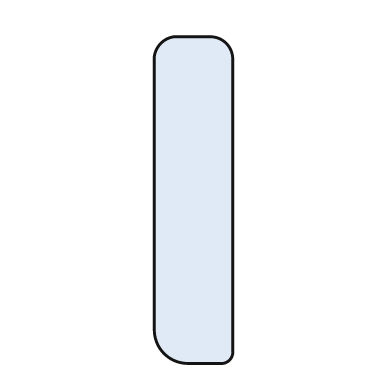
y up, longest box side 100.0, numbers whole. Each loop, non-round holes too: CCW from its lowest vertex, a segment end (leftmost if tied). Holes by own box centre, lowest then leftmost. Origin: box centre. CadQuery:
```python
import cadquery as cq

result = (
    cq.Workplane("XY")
    .moveTo(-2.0, -50.0)
    .lineTo(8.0, -50.0)
    .threePointArc((11.0, -49.0), (12.0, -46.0))
    .lineTo(12.0, 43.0)
    .threePointArc((10.0, 48.0), (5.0, 50.0))
    .lineTo(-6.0, 50.0)
    .threePointArc((-10.0, 48.0), (-12.0, 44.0))
    .lineTo(-12.0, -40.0)
    .threePointArc((-9.0, -47.0), (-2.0, -50.0))
    .close()
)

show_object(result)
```